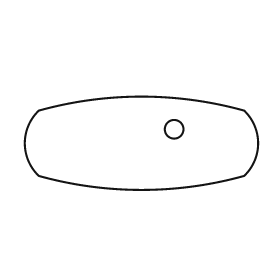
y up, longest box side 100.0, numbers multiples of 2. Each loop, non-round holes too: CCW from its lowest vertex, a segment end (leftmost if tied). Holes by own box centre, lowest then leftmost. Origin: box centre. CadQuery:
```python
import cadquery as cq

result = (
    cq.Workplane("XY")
    .moveTo(-44.0, -14.0)
    .threePointArc((0.0, -20.0), (44.0, -14.0))
    .threePointArc((50.0, 0.0), (44.0, 14.0))
    .threePointArc((0.0, 20.0), (-44.0, 14.0))
    .threePointArc((-50.0, 0.0), (-44.0, -14.0))
    .close()
    .moveTo(14.0, 6.0)
    .circle(4.0)
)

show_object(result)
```